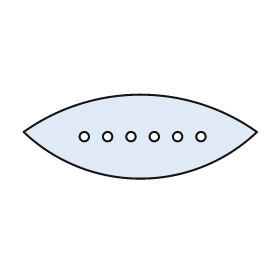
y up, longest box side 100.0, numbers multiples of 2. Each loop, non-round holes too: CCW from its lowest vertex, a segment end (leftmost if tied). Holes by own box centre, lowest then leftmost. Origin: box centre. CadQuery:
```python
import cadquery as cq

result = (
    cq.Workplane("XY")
    .moveTo(-50.0, 2.0)
    .threePointArc((0.0, -18.0), (50.0, 2.0))
    .threePointArc((0.0, 18.0), (-50.0, 2.0))
    .close()
    .moveTo(-24.0, 0.0)
    .circle(2.0)
    .moveTo(-14.0, 0.0)
    .circle(2.0)
    .moveTo(-4.0, 0.0)
    .circle(2.0)
    .moveTo(6.0, 0.0)
    .circle(2.0)
    .moveTo(16.0, 0.0)
    .circle(2.0)
    .moveTo(26.0, 0.0)
    .circle(2.0)
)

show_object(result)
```